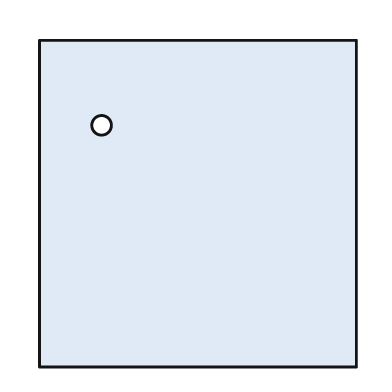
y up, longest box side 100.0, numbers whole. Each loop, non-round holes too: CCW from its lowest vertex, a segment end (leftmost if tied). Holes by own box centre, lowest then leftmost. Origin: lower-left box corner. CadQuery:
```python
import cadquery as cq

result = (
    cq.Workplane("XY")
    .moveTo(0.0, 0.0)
    .lineTo(97.0, 0.0)
    .lineTo(97.0, 100.0)
    .lineTo(0.0, 100.0)
    .close()
    .moveTo(19.0, 74.0)
    .circle(3.0)
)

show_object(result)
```